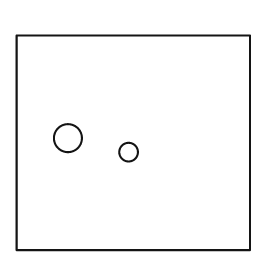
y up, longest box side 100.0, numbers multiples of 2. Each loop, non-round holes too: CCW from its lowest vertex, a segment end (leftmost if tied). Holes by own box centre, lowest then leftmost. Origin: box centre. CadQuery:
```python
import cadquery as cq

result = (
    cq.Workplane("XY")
    .moveTo(-50.0, -46.0)
    .lineTo(50.0, -46.0)
    .lineTo(50.0, 46.0)
    .lineTo(-50.0, 46.0)
    .close()
    .moveTo(-2.0, -4.0)
    .circle(4.0)
    .moveTo(-28.0, 2.0)
    .circle(6.0)
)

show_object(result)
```